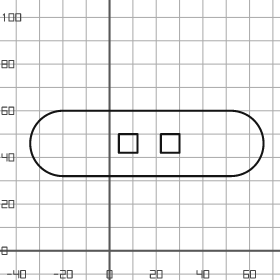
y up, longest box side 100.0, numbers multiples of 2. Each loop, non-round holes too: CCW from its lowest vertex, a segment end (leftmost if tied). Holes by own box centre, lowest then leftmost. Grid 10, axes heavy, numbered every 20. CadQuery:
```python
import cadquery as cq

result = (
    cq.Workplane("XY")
    .moveTo(-20.0, 32.0)
    .lineTo(52.0, 32.0)
    .threePointArc((66.0, 46.0), (52.0, 60.0))
    .lineTo(-20.0, 60.0)
    .threePointArc((-34.0, 46.0), (-20.0, 32.0))
    .close()
    .moveTo(4.0, 42.0)
    .lineTo(12.0, 42.0)
    .lineTo(12.0, 50.0)
    .lineTo(4.0, 50.0)
    .close()
    .moveTo(22.0, 42.0)
    .lineTo(30.0, 42.0)
    .lineTo(30.0, 50.0)
    .lineTo(22.0, 50.0)
    .close()
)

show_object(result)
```